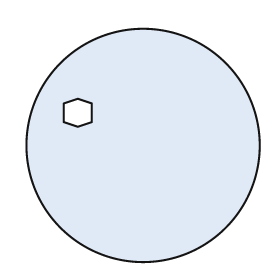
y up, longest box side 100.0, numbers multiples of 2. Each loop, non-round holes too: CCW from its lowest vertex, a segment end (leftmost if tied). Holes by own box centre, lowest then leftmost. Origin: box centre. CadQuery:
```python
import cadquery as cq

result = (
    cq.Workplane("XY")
    .moveTo(0.0, 0.0)
    .circle(50.0)
    .moveTo(-28.0, 8.0)
    .lineTo(-22.0, 10.0)
    .lineTo(-22.0, 18.0)
    .lineTo(-28.0, 20.0)
    .lineTo(-34.0, 18.0)
    .lineTo(-34.0, 10.0)
    .close()
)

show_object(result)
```